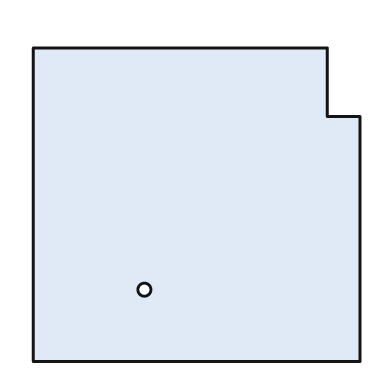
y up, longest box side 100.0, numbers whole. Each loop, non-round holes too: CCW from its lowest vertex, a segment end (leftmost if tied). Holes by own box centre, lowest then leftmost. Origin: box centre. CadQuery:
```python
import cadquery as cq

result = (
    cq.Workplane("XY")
    .moveTo(-50.0, -48.0)
    .lineTo(50.0, -48.0)
    .lineTo(50.0, 27.0)
    .lineTo(40.0, 27.0)
    .lineTo(40.0, 48.0)
    .lineTo(-50.0, 48.0)
    .close()
    .moveTo(-16.0, -26.0)
    .circle(2.0)
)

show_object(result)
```